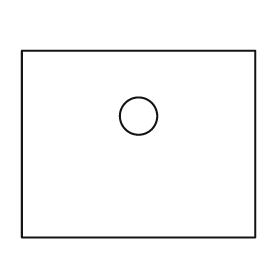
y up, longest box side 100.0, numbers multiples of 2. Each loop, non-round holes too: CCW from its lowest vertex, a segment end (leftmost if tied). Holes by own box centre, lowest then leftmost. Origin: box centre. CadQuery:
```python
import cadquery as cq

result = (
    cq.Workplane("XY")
    .moveTo(-50.0, -40.0)
    .lineTo(50.0, -40.0)
    .lineTo(50.0, 40.0)
    .lineTo(-50.0, 40.0)
    .close()
    .moveTo(0.0, 12.0)
    .circle(8.0)
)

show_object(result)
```